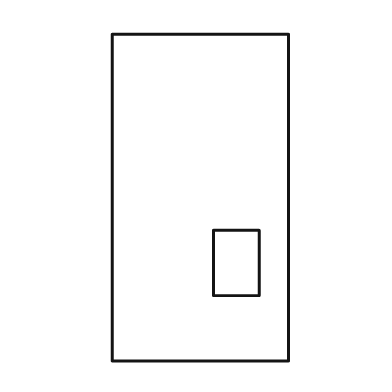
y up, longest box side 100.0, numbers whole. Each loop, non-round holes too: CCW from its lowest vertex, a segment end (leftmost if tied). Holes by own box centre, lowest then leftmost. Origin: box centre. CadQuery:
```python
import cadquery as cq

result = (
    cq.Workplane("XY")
    .moveTo(-27.0, -50.0)
    .lineTo(27.0, -50.0)
    .lineTo(27.0, 50.0)
    .lineTo(-27.0, 50.0)
    .close()
    .moveTo(4.0, -30.0)
    .lineTo(18.0, -30.0)
    .lineTo(18.0, -10.0)
    .lineTo(4.0, -10.0)
    .close()
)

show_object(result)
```